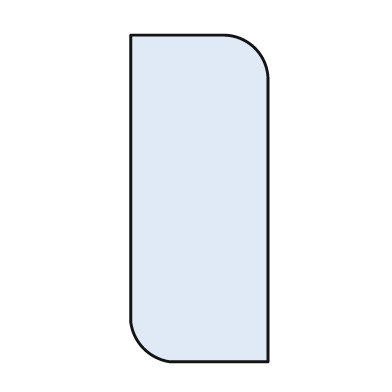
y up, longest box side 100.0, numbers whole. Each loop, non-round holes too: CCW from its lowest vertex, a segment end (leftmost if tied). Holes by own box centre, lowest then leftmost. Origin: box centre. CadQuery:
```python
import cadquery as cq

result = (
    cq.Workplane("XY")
    .moveTo(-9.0, -50.0)
    .lineTo(21.0, -50.0)
    .lineTo(21.0, 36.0)
    .threePointArc((17.0, 46.0), (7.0, 50.0))
    .lineTo(-21.0, 50.0)
    .lineTo(-21.0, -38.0)
    .threePointArc((-17.0, -46.0), (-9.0, -50.0))
    .close()
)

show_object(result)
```